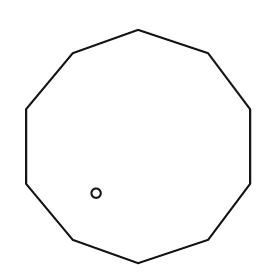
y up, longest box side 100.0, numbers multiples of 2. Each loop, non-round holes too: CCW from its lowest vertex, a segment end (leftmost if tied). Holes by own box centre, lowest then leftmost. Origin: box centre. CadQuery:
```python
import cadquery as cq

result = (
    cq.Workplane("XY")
    .moveTo(0.0, -50.0)
    .lineTo(30.0, -40.0)
    .lineTo(48.0, -16.0)
    .lineTo(48.0, 16.0)
    .lineTo(30.0, 40.0)
    .lineTo(0.0, 50.0)
    .lineTo(-28.0, 40.0)
    .lineTo(-48.0, 16.0)
    .lineTo(-48.0, -16.0)
    .lineTo(-28.0, -40.0)
    .close()
    .moveTo(-18.0, -20.0)
    .circle(2.0)
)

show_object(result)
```